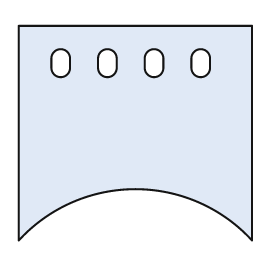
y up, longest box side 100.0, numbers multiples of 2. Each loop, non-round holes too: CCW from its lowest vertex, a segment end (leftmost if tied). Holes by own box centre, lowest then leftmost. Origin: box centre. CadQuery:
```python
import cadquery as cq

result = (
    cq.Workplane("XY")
    .moveTo(-50.0, -46.0)
    .threePointArc((0.0, -24.0), (50.0, -46.0))
    .lineTo(50.0, 46.0)
    .lineTo(-50.0, 46.0)
    .close()
    .moveTo(-36.0, 28.0)
    .threePointArc((-32.0, 24.0), (-28.0, 28.0))
    .lineTo(-28.0, 32.0)
    .threePointArc((-32.0, 36.0), (-36.0, 32.0))
    .close()
    .moveTo(-16.0, 28.0)
    .threePointArc((-12.0, 24.0), (-8.0, 28.0))
    .lineTo(-8.0, 32.0)
    .threePointArc((-12.0, 36.0), (-16.0, 32.0))
    .close()
    .moveTo(4.0, 28.0)
    .threePointArc((8.0, 24.0), (12.0, 28.0))
    .lineTo(12.0, 32.0)
    .threePointArc((8.0, 36.0), (4.0, 32.0))
    .close()
    .moveTo(24.0, 28.0)
    .threePointArc((28.0, 24.0), (32.0, 28.0))
    .lineTo(32.0, 32.0)
    .threePointArc((28.0, 36.0), (24.0, 32.0))
    .close()
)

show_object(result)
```